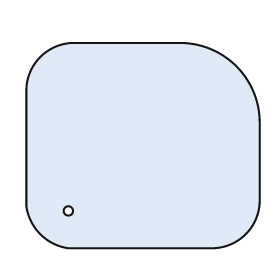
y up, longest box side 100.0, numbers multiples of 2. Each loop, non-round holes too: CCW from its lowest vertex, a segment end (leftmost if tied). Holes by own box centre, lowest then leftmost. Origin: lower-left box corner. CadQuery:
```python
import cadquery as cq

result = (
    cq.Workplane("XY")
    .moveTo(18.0, 0.0)
    .lineTo(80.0, 0.0)
    .threePointArc((94.0, 6.0), (100.0, 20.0))
    .lineTo(100.0, 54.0)
    .threePointArc((90.0, 78.0), (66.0, 88.0))
    .lineTo(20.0, 88.0)
    .threePointArc((6.0, 82.0), (0.0, 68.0))
    .lineTo(0.0, 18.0)
    .threePointArc((6.0, 6.0), (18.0, 0.0))
    .close()
    .moveTo(18.0, 16.0)
    .circle(2.0)
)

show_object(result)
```